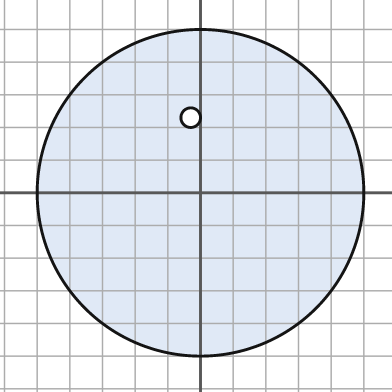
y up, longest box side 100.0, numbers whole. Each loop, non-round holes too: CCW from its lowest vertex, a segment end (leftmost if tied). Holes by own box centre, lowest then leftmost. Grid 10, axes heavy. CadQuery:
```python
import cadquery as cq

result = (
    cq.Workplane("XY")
    .moveTo(0.0, 0.0)
    .circle(50.0)
    .moveTo(-3.0, 23.0)
    .circle(3.0)
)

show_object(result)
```